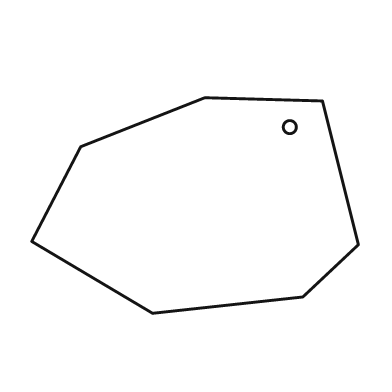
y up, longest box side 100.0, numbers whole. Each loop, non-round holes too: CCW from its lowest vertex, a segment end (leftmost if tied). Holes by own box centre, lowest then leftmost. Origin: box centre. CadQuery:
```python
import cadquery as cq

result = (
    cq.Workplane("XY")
    .moveTo(-13.0, -33.0)
    .lineTo(33.0, -28.0)
    .lineTo(50.0, -12.0)
    .lineTo(39.0, 32.0)
    .lineTo(3.0, 33.0)
    .lineTo(-35.0, 18.0)
    .lineTo(-50.0, -11.0)
    .close()
    .moveTo(29.0, 24.0)
    .circle(2.0)
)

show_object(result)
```